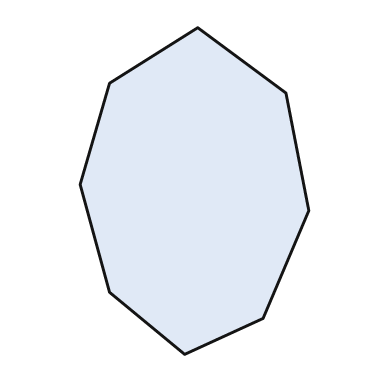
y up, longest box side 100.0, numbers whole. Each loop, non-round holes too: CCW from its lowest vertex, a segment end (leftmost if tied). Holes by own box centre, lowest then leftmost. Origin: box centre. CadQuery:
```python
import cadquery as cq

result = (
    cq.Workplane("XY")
    .moveTo(-3.0, -50.0)
    .lineTo(21.0, -39.0)
    .lineTo(35.0, -6.0)
    .lineTo(28.0, 30.0)
    .lineTo(1.0, 50.0)
    .lineTo(-26.0, 33.0)
    .lineTo(-35.0, 2.0)
    .lineTo(-26.0, -31.0)
    .close()
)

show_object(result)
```